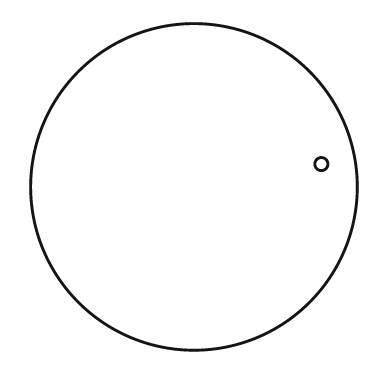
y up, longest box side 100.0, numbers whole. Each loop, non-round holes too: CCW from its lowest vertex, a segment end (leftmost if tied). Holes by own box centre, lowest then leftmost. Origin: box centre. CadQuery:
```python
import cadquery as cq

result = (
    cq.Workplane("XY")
    .moveTo(0.0, 0.0)
    .circle(50.0)
    .moveTo(39.0, 7.0)
    .circle(2.0)
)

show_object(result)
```